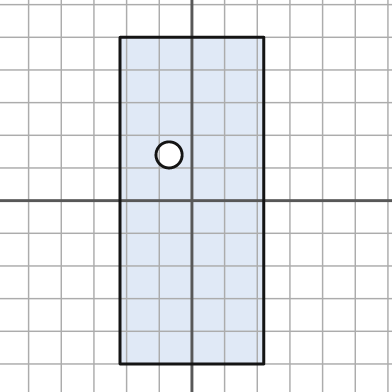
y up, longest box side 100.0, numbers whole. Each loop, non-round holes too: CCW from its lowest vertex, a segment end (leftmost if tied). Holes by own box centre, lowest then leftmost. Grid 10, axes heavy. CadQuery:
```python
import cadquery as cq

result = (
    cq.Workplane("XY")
    .moveTo(-22.0, -50.0)
    .lineTo(22.0, -50.0)
    .lineTo(22.0, 50.0)
    .lineTo(-22.0, 50.0)
    .close()
    .moveTo(-7.0, 14.0)
    .circle(4.0)
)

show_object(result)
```